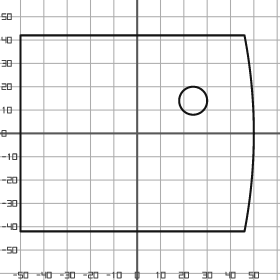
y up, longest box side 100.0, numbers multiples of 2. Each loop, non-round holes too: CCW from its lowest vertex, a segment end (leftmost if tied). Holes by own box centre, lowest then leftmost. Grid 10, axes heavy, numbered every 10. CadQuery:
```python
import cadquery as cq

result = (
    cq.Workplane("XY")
    .moveTo(-50.0, -42.0)
    .lineTo(46.0, -42.0)
    .threePointArc((50.0, 0.0), (46.0, 42.0))
    .lineTo(-50.0, 42.0)
    .close()
    .moveTo(24.0, 14.0)
    .circle(6.0)
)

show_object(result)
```